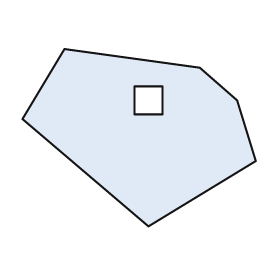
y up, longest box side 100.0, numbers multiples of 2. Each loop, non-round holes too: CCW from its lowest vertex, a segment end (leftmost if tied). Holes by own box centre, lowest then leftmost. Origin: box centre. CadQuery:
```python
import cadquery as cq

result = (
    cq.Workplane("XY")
    .moveTo(4.0, -38.0)
    .lineTo(50.0, -10.0)
    .lineTo(42.0, 16.0)
    .lineTo(26.0, 30.0)
    .lineTo(-32.0, 38.0)
    .lineTo(-50.0, 8.0)
    .close()
    .moveTo(-2.0, 10.0)
    .lineTo(10.0, 10.0)
    .lineTo(10.0, 22.0)
    .lineTo(-2.0, 22.0)
    .close()
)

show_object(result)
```